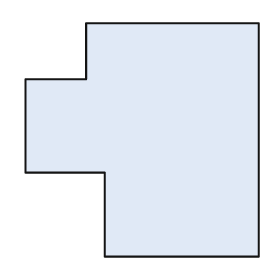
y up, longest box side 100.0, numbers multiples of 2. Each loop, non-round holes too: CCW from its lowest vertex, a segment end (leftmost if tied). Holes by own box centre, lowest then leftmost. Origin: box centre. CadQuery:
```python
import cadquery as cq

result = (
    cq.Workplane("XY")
    .moveTo(-16.0, -50.0)
    .lineTo(50.0, -50.0)
    .lineTo(50.0, 50.0)
    .lineTo(-24.0, 50.0)
    .lineTo(-24.0, 26.0)
    .lineTo(-50.0, 26.0)
    .lineTo(-50.0, -14.0)
    .lineTo(-16.0, -14.0)
    .close()
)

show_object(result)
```